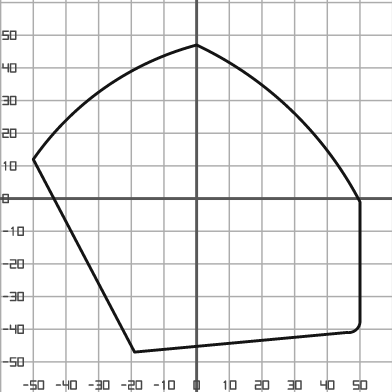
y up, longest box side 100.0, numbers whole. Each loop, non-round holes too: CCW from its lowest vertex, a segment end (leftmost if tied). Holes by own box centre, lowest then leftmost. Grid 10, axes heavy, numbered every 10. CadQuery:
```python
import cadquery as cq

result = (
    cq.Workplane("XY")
    .moveTo(-19.0, -47.0)
    .lineTo(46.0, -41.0)
    .threePointArc((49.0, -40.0), (50.0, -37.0))
    .lineTo(50.0, -1.0)
    .threePointArc((29.0, 27.0), (0.0, 47.0))
    .threePointArc((-28.0, 34.0), (-50.0, 12.0))
    .close()
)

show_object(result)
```